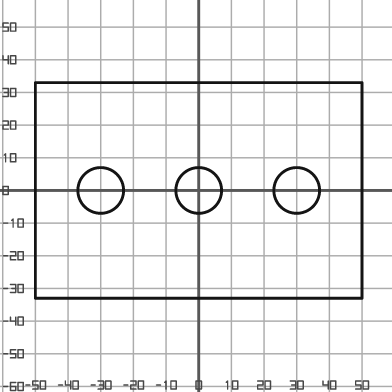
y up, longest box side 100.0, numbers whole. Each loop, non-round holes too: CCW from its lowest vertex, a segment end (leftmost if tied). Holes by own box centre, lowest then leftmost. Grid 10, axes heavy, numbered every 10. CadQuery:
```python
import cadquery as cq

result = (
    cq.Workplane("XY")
    .moveTo(-50.0, -33.0)
    .lineTo(50.0, -33.0)
    .lineTo(50.0, 33.0)
    .lineTo(-50.0, 33.0)
    .close()
    .moveTo(-30.0, 0.0)
    .circle(7.0)
    .moveTo(0.0, 0.0)
    .circle(7.0)
    .moveTo(30.0, 0.0)
    .circle(7.0)
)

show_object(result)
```